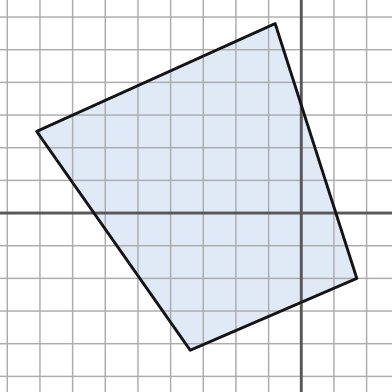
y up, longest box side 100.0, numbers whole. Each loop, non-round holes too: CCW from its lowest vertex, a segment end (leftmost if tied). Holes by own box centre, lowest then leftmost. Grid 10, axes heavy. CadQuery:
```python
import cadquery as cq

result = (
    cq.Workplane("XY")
    .moveTo(-34.0, -42.0)
    .lineTo(17.0, -20.0)
    .lineTo(-8.0, 58.0)
    .lineTo(-81.0, 25.0)
    .close()
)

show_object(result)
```